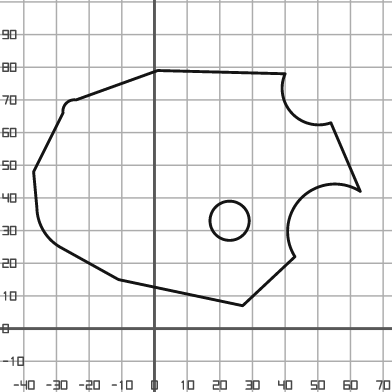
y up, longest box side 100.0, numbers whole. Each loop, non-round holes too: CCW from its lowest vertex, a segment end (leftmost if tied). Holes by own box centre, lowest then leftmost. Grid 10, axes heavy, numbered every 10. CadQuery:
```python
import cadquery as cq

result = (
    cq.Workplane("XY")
    .moveTo(27.0, 7.0)
    .lineTo(43.0, 22.0)
    .threePointArc((45.0, 40.0), (63.0, 42.0))
    .lineTo(54.0, 63.0)
    .threePointArc((42.0, 66.0), (40.0, 78.0))
    .lineTo(1.0, 79.0)
    .lineTo(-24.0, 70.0)
    .threePointArc((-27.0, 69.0), (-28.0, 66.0))
    .lineTo(-37.0, 48.0)
    .lineTo(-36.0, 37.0)
    .threePointArc((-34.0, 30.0), (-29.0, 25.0))
    .lineTo(-11.0, 15.0)
    .close()
    .moveTo(23.0, 33.0)
    .circle(6.0)
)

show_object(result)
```